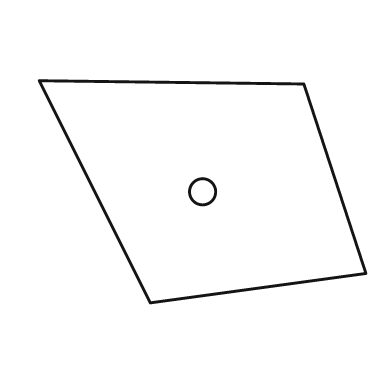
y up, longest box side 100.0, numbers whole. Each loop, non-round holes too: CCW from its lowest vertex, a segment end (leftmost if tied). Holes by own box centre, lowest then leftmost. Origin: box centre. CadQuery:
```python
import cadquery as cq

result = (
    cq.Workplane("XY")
    .moveTo(-16.0, -34.0)
    .lineTo(50.0, -25.0)
    .lineTo(31.0, 33.0)
    .lineTo(-50.0, 34.0)
    .close()
    .moveTo(0.0, 0.0)
    .circle(4.0)
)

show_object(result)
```